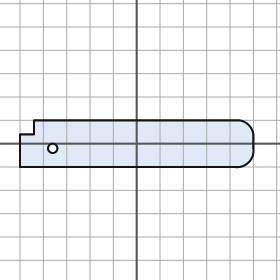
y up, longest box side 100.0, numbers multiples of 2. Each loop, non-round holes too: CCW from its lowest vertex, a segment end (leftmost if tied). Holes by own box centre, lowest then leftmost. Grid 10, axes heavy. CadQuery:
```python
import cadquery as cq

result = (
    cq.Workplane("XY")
    .moveTo(-50.0, -10.0)
    .lineTo(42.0, -10.0)
    .threePointArc((48.0, -8.0), (50.0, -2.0))
    .lineTo(50.0, 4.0)
    .threePointArc((48.0, 8.0), (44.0, 10.0))
    .lineTo(-44.0, 10.0)
    .lineTo(-44.0, 4.0)
    .lineTo(-50.0, 4.0)
    .close()
    .moveTo(-36.0, -2.0)
    .circle(2.0)
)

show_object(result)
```